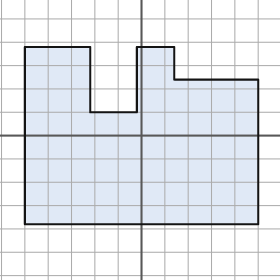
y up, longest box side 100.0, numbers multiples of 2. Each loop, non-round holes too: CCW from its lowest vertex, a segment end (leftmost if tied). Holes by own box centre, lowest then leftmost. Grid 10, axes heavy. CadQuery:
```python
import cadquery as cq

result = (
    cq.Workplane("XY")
    .moveTo(-50.0, -38.0)
    .lineTo(50.0, -38.0)
    .lineTo(50.0, 24.0)
    .lineTo(14.0, 24.0)
    .lineTo(14.0, 38.0)
    .lineTo(-2.0, 38.0)
    .lineTo(-2.0, 10.0)
    .lineTo(-22.0, 10.0)
    .lineTo(-22.0, 38.0)
    .lineTo(-50.0, 38.0)
    .close()
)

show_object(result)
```